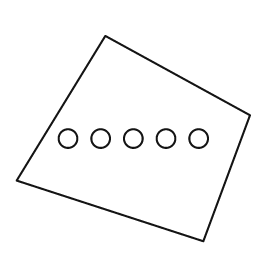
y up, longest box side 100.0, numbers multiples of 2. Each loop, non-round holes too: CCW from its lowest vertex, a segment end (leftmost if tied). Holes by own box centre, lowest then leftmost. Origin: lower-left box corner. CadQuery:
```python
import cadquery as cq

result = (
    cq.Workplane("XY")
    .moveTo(80.0, 0.0)
    .lineTo(100.0, 54.0)
    .lineTo(38.0, 88.0)
    .lineTo(0.0, 26.0)
    .close()
    .moveTo(22.0, 44.0)
    .circle(4.0)
    .moveTo(36.0, 44.0)
    .circle(4.0)
    .moveTo(50.0, 44.0)
    .circle(4.0)
    .moveTo(64.0, 44.0)
    .circle(4.0)
    .moveTo(78.0, 44.0)
    .circle(4.0)
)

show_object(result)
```